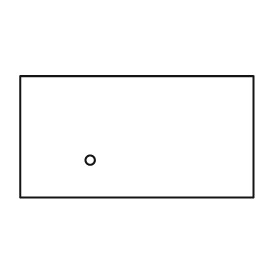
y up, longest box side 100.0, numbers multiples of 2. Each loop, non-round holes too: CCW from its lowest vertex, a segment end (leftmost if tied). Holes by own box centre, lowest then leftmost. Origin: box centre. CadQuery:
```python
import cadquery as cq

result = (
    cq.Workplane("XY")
    .moveTo(-50.0, -26.0)
    .lineTo(50.0, -26.0)
    .lineTo(50.0, 26.0)
    .lineTo(-50.0, 26.0)
    .close()
    .moveTo(-20.0, -10.0)
    .circle(2.0)
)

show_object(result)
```